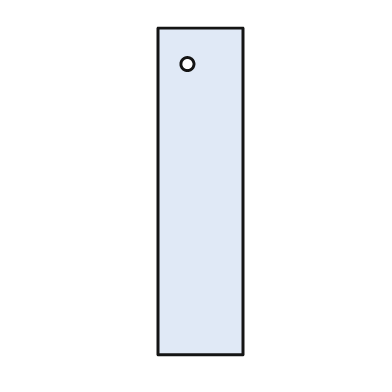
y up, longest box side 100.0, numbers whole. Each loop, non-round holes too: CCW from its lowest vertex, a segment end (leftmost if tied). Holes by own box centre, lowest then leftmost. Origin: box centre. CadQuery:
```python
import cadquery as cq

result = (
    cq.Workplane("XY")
    .moveTo(-13.0, -50.0)
    .lineTo(13.0, -50.0)
    .lineTo(13.0, 50.0)
    .lineTo(-13.0, 50.0)
    .close()
    .moveTo(-4.0, 39.0)
    .circle(2.0)
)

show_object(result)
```